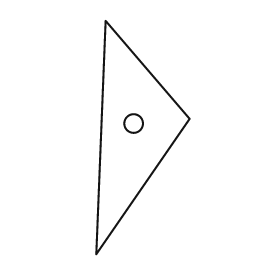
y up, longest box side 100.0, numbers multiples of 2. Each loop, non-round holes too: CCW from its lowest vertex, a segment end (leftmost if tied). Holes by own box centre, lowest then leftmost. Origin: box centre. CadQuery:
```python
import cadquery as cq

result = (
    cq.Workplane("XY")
    .moveTo(-20.0, -50.0)
    .lineTo(20.0, 8.0)
    .lineTo(-16.0, 50.0)
    .close()
    .moveTo(-4.0, 6.0)
    .circle(4.0)
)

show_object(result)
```